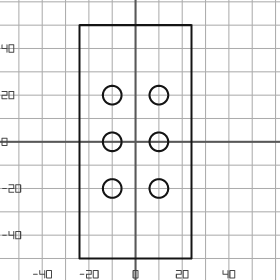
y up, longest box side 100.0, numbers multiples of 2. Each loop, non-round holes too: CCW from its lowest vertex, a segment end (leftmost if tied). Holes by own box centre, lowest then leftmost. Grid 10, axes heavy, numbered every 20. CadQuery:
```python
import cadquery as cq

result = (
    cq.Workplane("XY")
    .moveTo(-24.0, -50.0)
    .lineTo(24.0, -50.0)
    .lineTo(24.0, 50.0)
    .lineTo(-24.0, 50.0)
    .close()
    .moveTo(-10.0, -20.0)
    .circle(4.0)
    .moveTo(10.0, -20.0)
    .circle(4.0)
    .moveTo(-10.0, 0.0)
    .circle(4.0)
    .moveTo(10.0, 0.0)
    .circle(4.0)
    .moveTo(-10.0, 20.0)
    .circle(4.0)
    .moveTo(10.0, 20.0)
    .circle(4.0)
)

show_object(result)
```